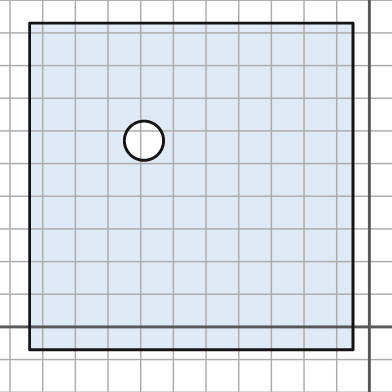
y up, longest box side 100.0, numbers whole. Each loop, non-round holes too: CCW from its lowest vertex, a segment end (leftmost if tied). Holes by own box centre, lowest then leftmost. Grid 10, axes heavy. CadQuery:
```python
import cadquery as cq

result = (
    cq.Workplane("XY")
    .moveTo(-104.0, -7.0)
    .lineTo(-5.0, -7.0)
    .lineTo(-5.0, 93.0)
    .lineTo(-104.0, 93.0)
    .close()
    .moveTo(-69.0, 57.0)
    .circle(6.0)
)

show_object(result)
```